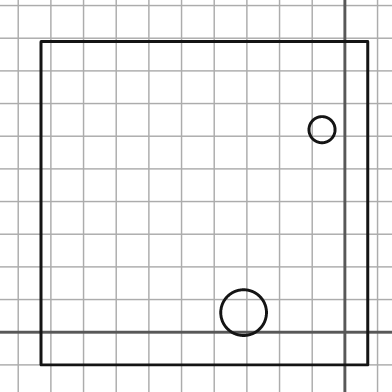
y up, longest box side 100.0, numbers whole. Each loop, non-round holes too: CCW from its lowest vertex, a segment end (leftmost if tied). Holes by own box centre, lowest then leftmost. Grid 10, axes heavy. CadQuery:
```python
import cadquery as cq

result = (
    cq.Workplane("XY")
    .moveTo(-93.0, -10.0)
    .lineTo(7.0, -10.0)
    .lineTo(7.0, 89.0)
    .lineTo(-93.0, 89.0)
    .close()
    .moveTo(-31.0, 6.0)
    .circle(7.0)
    .moveTo(-7.0, 62.0)
    .circle(4.0)
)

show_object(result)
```